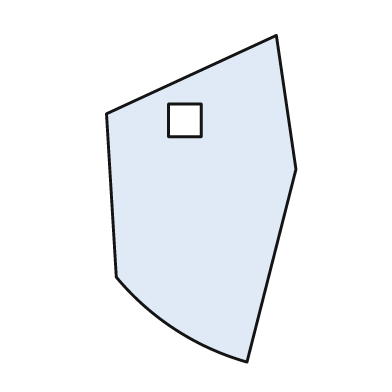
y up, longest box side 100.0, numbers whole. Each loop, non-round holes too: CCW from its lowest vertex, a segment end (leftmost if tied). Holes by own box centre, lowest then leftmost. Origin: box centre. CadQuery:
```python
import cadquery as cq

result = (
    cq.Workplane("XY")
    .moveTo(14.0, -50.0)
    .lineTo(29.0, 9.0)
    .lineTo(23.0, 50.0)
    .lineTo(-29.0, 26.0)
    .lineTo(-26.0, -24.0)
    .threePointArc((-8.0, -40.0), (14.0, -50.0))
    .close()
    .moveTo(-10.0, 19.0)
    .lineTo(0.0, 19.0)
    .lineTo(0.0, 29.0)
    .lineTo(-10.0, 29.0)
    .close()
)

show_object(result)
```